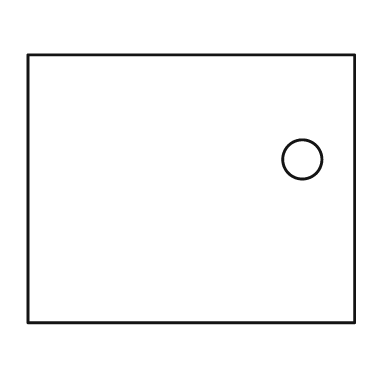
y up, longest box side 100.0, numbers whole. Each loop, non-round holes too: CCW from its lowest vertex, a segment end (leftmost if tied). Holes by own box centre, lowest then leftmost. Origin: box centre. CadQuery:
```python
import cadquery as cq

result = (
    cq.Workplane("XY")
    .moveTo(-50.0, -41.0)
    .lineTo(50.0, -41.0)
    .lineTo(50.0, 41.0)
    .lineTo(-50.0, 41.0)
    .close()
    .moveTo(34.0, 9.0)
    .circle(6.0)
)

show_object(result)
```